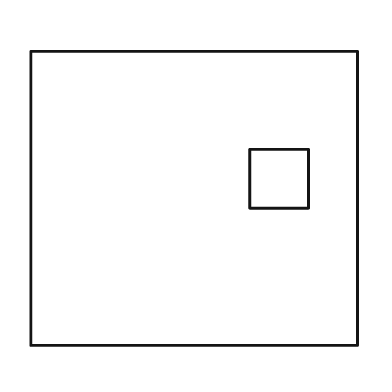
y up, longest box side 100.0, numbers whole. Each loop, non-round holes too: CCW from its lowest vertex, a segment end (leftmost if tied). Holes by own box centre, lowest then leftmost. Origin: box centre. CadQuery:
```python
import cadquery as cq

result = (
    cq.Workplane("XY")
    .moveTo(-50.0, -45.0)
    .lineTo(50.0, -45.0)
    .lineTo(50.0, 45.0)
    .lineTo(-50.0, 45.0)
    .close()
    .moveTo(17.0, -3.0)
    .lineTo(35.0, -3.0)
    .lineTo(35.0, 15.0)
    .lineTo(17.0, 15.0)
    .close()
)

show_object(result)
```